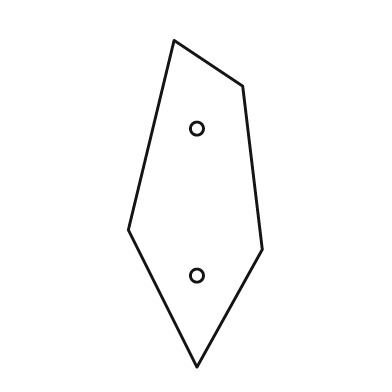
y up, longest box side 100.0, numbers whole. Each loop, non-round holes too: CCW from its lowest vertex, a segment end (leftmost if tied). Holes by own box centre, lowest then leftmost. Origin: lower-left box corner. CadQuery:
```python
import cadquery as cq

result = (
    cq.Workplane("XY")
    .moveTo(21.0, 0.0)
    .lineTo(41.0, 36.0)
    .lineTo(35.0, 86.0)
    .lineTo(14.0, 100.0)
    .lineTo(0.0, 42.0)
    .close()
    .moveTo(21.0, 28.0)
    .circle(2.0)
    .moveTo(21.0, 73.0)
    .circle(2.0)
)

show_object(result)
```